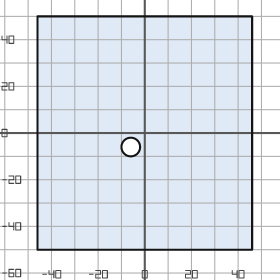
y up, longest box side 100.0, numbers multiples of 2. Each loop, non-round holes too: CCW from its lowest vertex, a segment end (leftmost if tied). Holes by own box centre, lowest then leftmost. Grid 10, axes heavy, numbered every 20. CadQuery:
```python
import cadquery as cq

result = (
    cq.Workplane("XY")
    .moveTo(-46.0, -50.0)
    .lineTo(46.0, -50.0)
    .lineTo(46.0, 50.0)
    .lineTo(-46.0, 50.0)
    .close()
    .moveTo(-6.0, -6.0)
    .circle(4.0)
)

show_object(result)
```